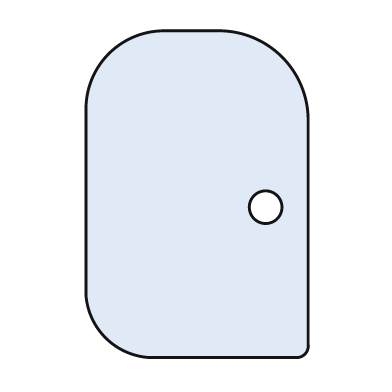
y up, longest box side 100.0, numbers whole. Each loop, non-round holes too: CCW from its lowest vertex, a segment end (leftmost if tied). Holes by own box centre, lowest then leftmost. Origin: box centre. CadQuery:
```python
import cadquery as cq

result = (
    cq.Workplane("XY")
    .moveTo(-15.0, -50.0)
    .lineTo(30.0, -50.0)
    .threePointArc((33.0, -49.0), (34.0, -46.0))
    .lineTo(34.0, 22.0)
    .threePointArc((26.0, 42.0), (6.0, 50.0))
    .lineTo(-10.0, 50.0)
    .threePointArc((-27.0, 43.0), (-34.0, 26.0))
    .lineTo(-34.0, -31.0)
    .threePointArc((-28.0, -44.0), (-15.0, -50.0))
    .close()
    .moveTo(21.0, -4.0)
    .circle(5.0)
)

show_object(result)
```